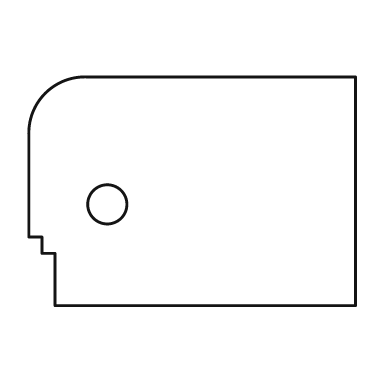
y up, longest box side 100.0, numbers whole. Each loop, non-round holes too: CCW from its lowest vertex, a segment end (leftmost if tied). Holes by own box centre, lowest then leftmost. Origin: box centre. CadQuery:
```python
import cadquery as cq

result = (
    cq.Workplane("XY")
    .moveTo(-42.0, -35.0)
    .lineTo(50.0, -35.0)
    .lineTo(50.0, 35.0)
    .lineTo(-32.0, 35.0)
    .threePointArc((-45.0, 30.0), (-50.0, 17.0))
    .lineTo(-50.0, -14.0)
    .lineTo(-46.0, -14.0)
    .lineTo(-46.0, -19.0)
    .lineTo(-42.0, -19.0)
    .close()
    .moveTo(-26.0, -4.0)
    .circle(6.0)
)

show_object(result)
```